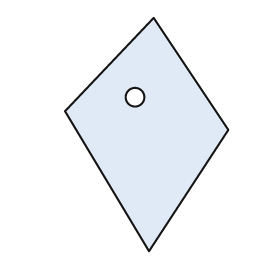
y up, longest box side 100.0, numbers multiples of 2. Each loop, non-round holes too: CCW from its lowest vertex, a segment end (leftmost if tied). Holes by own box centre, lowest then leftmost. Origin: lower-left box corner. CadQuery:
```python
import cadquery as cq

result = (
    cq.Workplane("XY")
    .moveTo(36.0, 0.0)
    .lineTo(70.0, 52.0)
    .lineTo(38.0, 100.0)
    .lineTo(0.0, 60.0)
    .close()
    .moveTo(30.0, 66.0)
    .circle(4.0)
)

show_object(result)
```